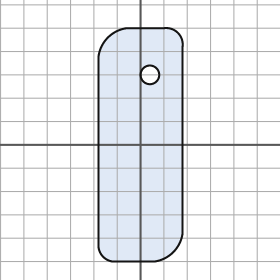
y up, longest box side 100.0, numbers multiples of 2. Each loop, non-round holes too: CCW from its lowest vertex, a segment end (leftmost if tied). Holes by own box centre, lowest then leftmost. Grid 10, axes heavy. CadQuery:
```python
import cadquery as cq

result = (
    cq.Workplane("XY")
    .moveTo(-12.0, -50.0)
    .lineTo(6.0, -50.0)
    .threePointArc((14.0, -46.0), (18.0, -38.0))
    .lineTo(18.0, 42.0)
    .threePointArc((16.0, 48.0), (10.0, 50.0))
    .lineTo(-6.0, 50.0)
    .threePointArc((-14.0, 46.0), (-18.0, 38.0))
    .lineTo(-18.0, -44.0)
    .threePointArc((-16.0, -48.0), (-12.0, -50.0))
    .close()
    .moveTo(4.0, 30.0)
    .circle(4.0)
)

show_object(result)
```